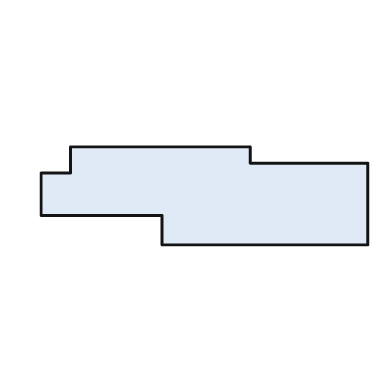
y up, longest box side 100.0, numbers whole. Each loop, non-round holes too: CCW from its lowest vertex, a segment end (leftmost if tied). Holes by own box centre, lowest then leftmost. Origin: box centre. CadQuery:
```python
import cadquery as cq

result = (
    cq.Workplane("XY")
    .moveTo(-13.0, -15.0)
    .lineTo(50.0, -15.0)
    .lineTo(50.0, 10.0)
    .lineTo(14.0, 10.0)
    .lineTo(14.0, 15.0)
    .lineTo(-41.0, 15.0)
    .lineTo(-41.0, 7.0)
    .lineTo(-50.0, 7.0)
    .lineTo(-50.0, -6.0)
    .lineTo(-13.0, -6.0)
    .close()
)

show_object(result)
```